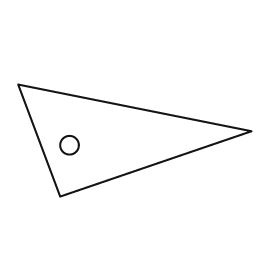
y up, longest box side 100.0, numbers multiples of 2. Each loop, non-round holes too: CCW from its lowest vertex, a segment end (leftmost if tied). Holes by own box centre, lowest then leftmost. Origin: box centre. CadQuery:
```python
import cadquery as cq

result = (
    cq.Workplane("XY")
    .moveTo(-32.0, -24.0)
    .lineTo(50.0, 4.0)
    .lineTo(-50.0, 24.0)
    .close()
    .moveTo(-28.0, -2.0)
    .circle(4.0)
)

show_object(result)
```